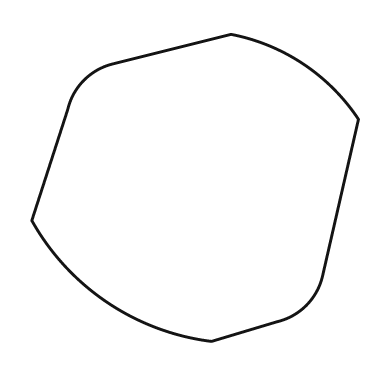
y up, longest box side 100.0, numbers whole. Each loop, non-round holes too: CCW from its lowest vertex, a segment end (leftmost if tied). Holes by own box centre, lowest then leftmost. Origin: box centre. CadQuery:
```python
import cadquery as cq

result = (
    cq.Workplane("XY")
    .moveTo(5.0, -47.0)
    .lineTo(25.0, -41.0)
    .threePointArc((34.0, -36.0), (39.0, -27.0))
    .lineTo(50.0, 21.0)
    .threePointArc((33.0, 38.0), (11.0, 47.0))
    .lineTo(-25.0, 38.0)
    .threePointArc((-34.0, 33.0), (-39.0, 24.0))
    .lineTo(-50.0, -10.0)
    .threePointArc((-27.0, -35.0), (5.0, -47.0))
    .close()
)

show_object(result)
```